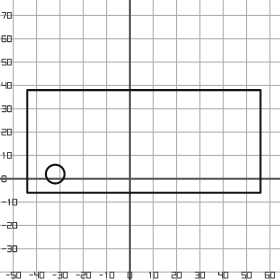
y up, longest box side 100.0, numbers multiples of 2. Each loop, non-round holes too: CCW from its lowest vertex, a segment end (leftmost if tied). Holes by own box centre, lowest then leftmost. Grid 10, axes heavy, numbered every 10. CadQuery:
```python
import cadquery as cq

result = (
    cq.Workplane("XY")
    .moveTo(-44.0, -6.0)
    .lineTo(56.0, -6.0)
    .lineTo(56.0, 38.0)
    .lineTo(-44.0, 38.0)
    .close()
    .moveTo(-32.0, 2.0)
    .circle(4.0)
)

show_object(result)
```